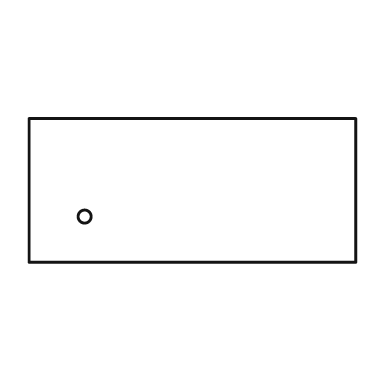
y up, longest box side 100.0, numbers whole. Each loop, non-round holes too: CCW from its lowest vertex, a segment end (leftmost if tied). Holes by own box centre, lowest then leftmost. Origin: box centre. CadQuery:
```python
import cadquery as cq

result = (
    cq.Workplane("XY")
    .moveTo(-50.0, -22.0)
    .lineTo(50.0, -22.0)
    .lineTo(50.0, 22.0)
    .lineTo(-50.0, 22.0)
    .close()
    .moveTo(-33.0, -8.0)
    .circle(2.0)
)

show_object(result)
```